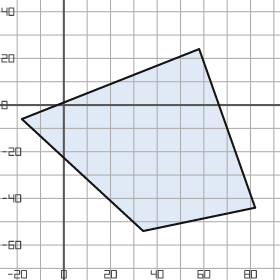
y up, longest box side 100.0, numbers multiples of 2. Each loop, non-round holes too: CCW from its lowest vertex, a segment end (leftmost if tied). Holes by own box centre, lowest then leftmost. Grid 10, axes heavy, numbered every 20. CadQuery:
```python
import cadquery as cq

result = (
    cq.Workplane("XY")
    .moveTo(34.0, -54.0)
    .lineTo(82.0, -44.0)
    .lineTo(58.0, 24.0)
    .lineTo(-18.0, -6.0)
    .close()
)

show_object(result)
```